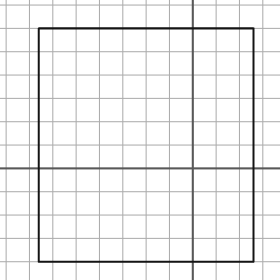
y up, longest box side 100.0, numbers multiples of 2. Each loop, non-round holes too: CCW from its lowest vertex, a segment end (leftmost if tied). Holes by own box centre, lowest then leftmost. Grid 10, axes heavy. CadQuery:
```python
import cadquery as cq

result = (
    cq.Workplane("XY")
    .moveTo(-66.0, -40.0)
    .lineTo(26.0, -40.0)
    .lineTo(26.0, 60.0)
    .lineTo(-66.0, 60.0)
    .close()
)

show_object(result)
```